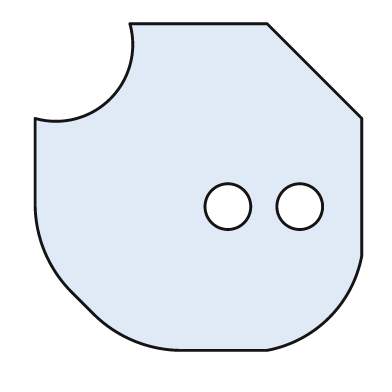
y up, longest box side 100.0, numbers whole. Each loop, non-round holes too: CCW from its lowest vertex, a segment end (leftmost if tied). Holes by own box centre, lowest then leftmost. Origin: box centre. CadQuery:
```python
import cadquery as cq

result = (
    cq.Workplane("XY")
    .moveTo(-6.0, -50.0)
    .lineTo(21.0, -50.0)
    .threePointArc((40.0, -40.0), (50.0, -21.0))
    .lineTo(50.0, 21.0)
    .lineTo(21.0, 50.0)
    .lineTo(-21.0, 50.0)
    .threePointArc((-27.0, 27.0), (-50.0, 21.0))
    .lineTo(-50.0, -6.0)
    .threePointArc((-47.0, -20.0), (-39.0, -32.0))
    .lineTo(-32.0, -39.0)
    .threePointArc((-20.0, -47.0), (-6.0, -50.0))
    .close()
    .moveTo(9.0, -6.0)
    .circle(7.0)
    .moveTo(31.0, -6.0)
    .circle(7.0)
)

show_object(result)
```